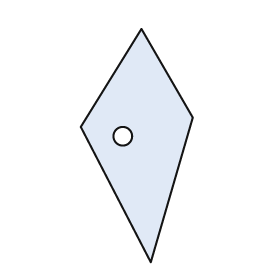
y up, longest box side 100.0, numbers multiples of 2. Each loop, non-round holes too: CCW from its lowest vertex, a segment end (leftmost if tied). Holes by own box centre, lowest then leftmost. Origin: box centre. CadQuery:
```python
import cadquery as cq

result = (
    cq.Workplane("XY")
    .moveTo(6.0, -50.0)
    .lineTo(24.0, 12.0)
    .lineTo(2.0, 50.0)
    .lineTo(-24.0, 8.0)
    .close()
    .moveTo(-6.0, 4.0)
    .circle(4.0)
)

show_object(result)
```